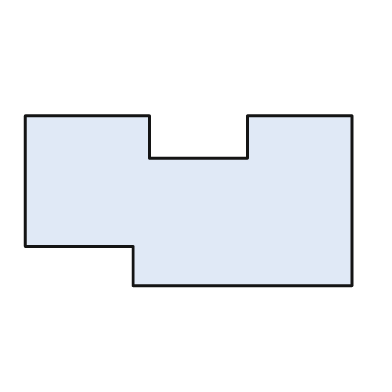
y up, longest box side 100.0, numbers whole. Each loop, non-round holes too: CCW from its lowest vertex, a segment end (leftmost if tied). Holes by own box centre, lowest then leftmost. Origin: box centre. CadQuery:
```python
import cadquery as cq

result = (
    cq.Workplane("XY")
    .moveTo(-17.0, -26.0)
    .lineTo(50.0, -26.0)
    .lineTo(50.0, 26.0)
    .lineTo(18.0, 26.0)
    .lineTo(18.0, 13.0)
    .lineTo(-12.0, 13.0)
    .lineTo(-12.0, 26.0)
    .lineTo(-50.0, 26.0)
    .lineTo(-50.0, -14.0)
    .lineTo(-17.0, -14.0)
    .close()
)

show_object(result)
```